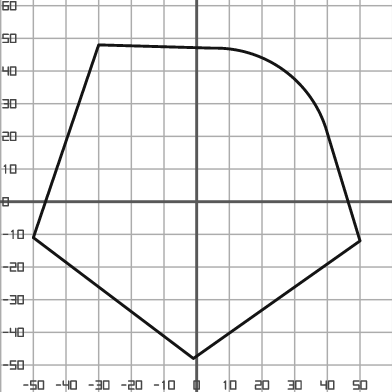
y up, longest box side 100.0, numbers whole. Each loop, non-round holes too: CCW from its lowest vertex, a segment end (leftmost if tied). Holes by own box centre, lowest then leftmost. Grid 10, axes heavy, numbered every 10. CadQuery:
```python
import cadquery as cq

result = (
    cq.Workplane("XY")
    .moveTo(-1.0, -48.0)
    .lineTo(50.0, -12.0)
    .lineTo(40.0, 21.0)
    .threePointArc((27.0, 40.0), (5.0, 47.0))
    .lineTo(-30.0, 48.0)
    .lineTo(-50.0, -11.0)
    .close()
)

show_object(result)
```